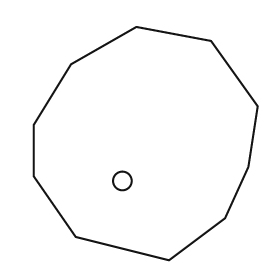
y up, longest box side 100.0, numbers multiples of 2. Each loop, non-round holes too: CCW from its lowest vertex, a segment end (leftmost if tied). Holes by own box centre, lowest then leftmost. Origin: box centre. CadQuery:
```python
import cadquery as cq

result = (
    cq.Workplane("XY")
    .moveTo(10.0, -50.0)
    .lineTo(34.0, -32.0)
    .lineTo(44.0, -10.0)
    .lineTo(48.0, 16.0)
    .lineTo(28.0, 44.0)
    .lineTo(-4.0, 50.0)
    .lineTo(-32.0, 34.0)
    .lineTo(-48.0, 8.0)
    .lineTo(-48.0, -14.0)
    .lineTo(-30.0, -40.0)
    .close()
    .moveTo(-10.0, -16.0)
    .circle(4.0)
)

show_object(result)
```